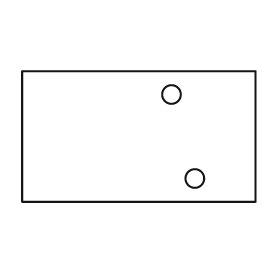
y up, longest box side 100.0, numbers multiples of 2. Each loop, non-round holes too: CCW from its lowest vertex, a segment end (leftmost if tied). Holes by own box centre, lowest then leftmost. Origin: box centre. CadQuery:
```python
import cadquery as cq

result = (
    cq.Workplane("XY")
    .moveTo(-50.0, -28.0)
    .lineTo(50.0, -28.0)
    .lineTo(50.0, 28.0)
    .lineTo(-50.0, 28.0)
    .close()
    .moveTo(24.0, -18.0)
    .circle(4.0)
    .moveTo(14.0, 18.0)
    .circle(4.0)
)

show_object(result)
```